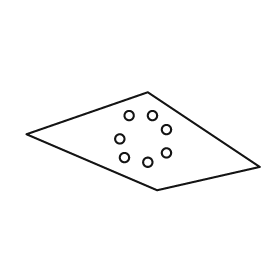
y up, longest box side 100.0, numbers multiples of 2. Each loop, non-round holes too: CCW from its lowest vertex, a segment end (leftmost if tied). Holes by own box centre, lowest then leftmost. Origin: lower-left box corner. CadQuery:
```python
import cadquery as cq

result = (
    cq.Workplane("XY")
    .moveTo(56.0, 0.0)
    .lineTo(100.0, 10.0)
    .lineTo(52.0, 42.0)
    .lineTo(0.0, 24.0)
    .close()
    .moveTo(52.0, 12.0)
    .circle(2.0)
    .moveTo(42.0, 14.0)
    .circle(2.0)
    .moveTo(60.0, 16.0)
    .circle(2.0)
    .moveTo(40.0, 22.0)
    .circle(2.0)
    .moveTo(60.0, 26.0)
    .circle(2.0)
    .moveTo(44.0, 32.0)
    .circle(2.0)
    .moveTo(54.0, 32.0)
    .circle(2.0)
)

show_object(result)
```